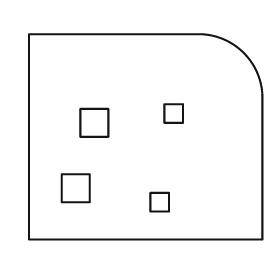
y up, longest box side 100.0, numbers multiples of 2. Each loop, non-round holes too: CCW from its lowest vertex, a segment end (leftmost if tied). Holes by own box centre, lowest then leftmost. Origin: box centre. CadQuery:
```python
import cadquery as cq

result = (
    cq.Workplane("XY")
    .moveTo(-50.0, -44.0)
    .lineTo(50.0, -44.0)
    .lineTo(50.0, 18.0)
    .threePointArc((42.0, 36.0), (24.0, 44.0))
    .lineTo(-50.0, 44.0)
    .close()
    .moveTo(2.0, -32.0)
    .lineTo(10.0, -32.0)
    .lineTo(10.0, -24.0)
    .lineTo(2.0, -24.0)
    .close()
    .moveTo(-36.0, -28.0)
    .lineTo(-24.0, -28.0)
    .lineTo(-24.0, -16.0)
    .lineTo(-36.0, -16.0)
    .close()
    .moveTo(-28.0, 0.0)
    .lineTo(-16.0, 0.0)
    .lineTo(-16.0, 12.0)
    .lineTo(-28.0, 12.0)
    .close()
    .moveTo(8.0, 6.0)
    .lineTo(16.0, 6.0)
    .lineTo(16.0, 14.0)
    .lineTo(8.0, 14.0)
    .close()
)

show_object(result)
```